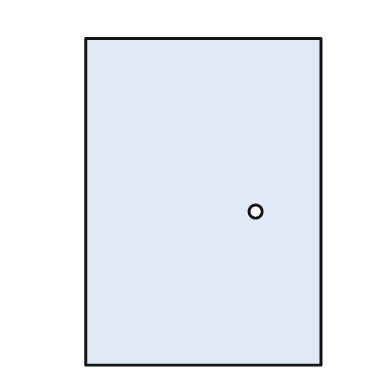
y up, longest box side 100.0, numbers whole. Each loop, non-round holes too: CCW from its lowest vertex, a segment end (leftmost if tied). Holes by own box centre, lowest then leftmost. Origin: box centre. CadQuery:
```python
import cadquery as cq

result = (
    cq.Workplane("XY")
    .moveTo(-36.0, -50.0)
    .lineTo(36.0, -50.0)
    .lineTo(36.0, 50.0)
    .lineTo(-36.0, 50.0)
    .close()
    .moveTo(16.0, -3.0)
    .circle(2.0)
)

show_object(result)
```